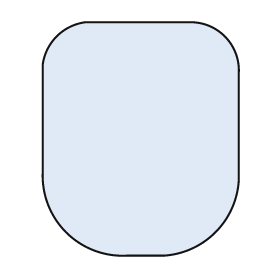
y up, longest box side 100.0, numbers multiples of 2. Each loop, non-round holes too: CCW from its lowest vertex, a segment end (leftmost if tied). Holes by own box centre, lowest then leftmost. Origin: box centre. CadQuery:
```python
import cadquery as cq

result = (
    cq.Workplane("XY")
    .moveTo(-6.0, -50.0)
    .lineTo(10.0, -50.0)
    .threePointArc((32.0, -40.0), (42.0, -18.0))
    .lineTo(42.0, 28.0)
    .threePointArc((36.0, 44.0), (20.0, 50.0))
    .lineTo(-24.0, 50.0)
    .threePointArc((-36.0, 44.0), (-42.0, 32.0))
    .lineTo(-42.0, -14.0)
    .threePointArc((-32.0, -40.0), (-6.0, -50.0))
    .close()
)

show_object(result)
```